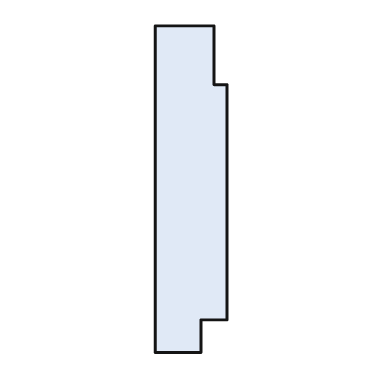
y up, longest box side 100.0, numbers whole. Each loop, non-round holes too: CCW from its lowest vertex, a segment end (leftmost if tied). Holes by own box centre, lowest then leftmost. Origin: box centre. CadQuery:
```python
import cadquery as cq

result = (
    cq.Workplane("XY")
    .moveTo(-11.0, -50.0)
    .lineTo(3.0, -50.0)
    .lineTo(3.0, -40.0)
    .lineTo(11.0, -40.0)
    .lineTo(11.0, 32.0)
    .lineTo(7.0, 32.0)
    .lineTo(7.0, 50.0)
    .lineTo(-11.0, 50.0)
    .close()
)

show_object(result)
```